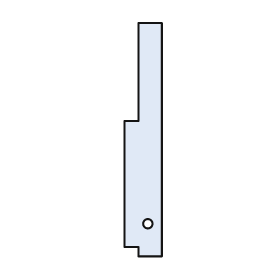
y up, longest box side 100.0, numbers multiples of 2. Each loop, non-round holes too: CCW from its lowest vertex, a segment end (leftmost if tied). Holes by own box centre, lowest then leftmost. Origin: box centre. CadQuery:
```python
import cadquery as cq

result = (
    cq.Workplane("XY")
    .moveTo(-2.0, -50.0)
    .lineTo(8.0, -50.0)
    .lineTo(8.0, 50.0)
    .lineTo(-2.0, 50.0)
    .lineTo(-2.0, 8.0)
    .lineTo(-8.0, 8.0)
    .lineTo(-8.0, -46.0)
    .lineTo(-2.0, -46.0)
    .close()
    .moveTo(2.0, -36.0)
    .circle(2.0)
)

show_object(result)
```